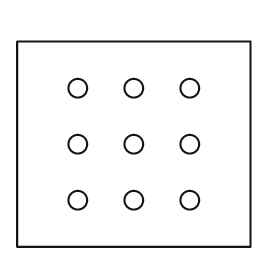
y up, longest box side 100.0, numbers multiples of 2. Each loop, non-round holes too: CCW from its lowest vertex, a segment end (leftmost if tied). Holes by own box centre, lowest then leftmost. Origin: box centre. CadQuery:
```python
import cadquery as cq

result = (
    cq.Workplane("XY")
    .moveTo(-50.0, -44.0)
    .lineTo(50.0, -44.0)
    .lineTo(50.0, 44.0)
    .lineTo(-50.0, 44.0)
    .close()
    .moveTo(-24.0, -24.0)
    .circle(4.0)
    .moveTo(0.0, -24.0)
    .circle(4.0)
    .moveTo(24.0, -24.0)
    .circle(4.0)
    .moveTo(-24.0, 0.0)
    .circle(4.0)
    .moveTo(0.0, 0.0)
    .circle(4.0)
    .moveTo(24.0, 0.0)
    .circle(4.0)
    .moveTo(-24.0, 24.0)
    .circle(4.0)
    .moveTo(0.0, 24.0)
    .circle(4.0)
    .moveTo(24.0, 24.0)
    .circle(4.0)
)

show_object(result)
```